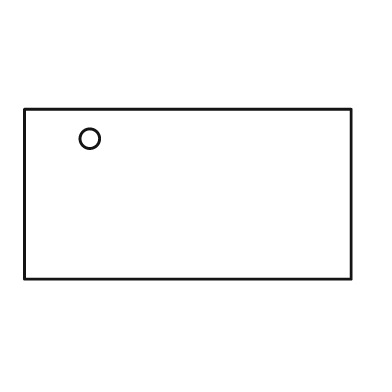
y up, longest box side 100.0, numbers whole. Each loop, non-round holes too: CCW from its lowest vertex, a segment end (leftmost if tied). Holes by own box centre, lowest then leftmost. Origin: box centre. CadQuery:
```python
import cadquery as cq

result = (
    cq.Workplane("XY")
    .moveTo(-50.0, -26.0)
    .lineTo(50.0, -26.0)
    .lineTo(50.0, 26.0)
    .lineTo(-50.0, 26.0)
    .close()
    .moveTo(-30.0, 17.0)
    .circle(3.0)
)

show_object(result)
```